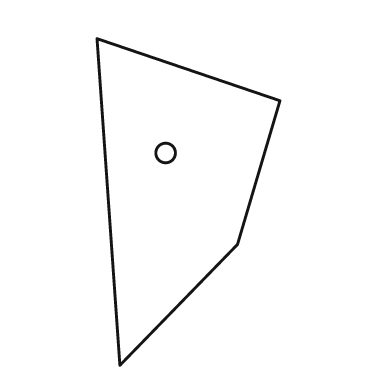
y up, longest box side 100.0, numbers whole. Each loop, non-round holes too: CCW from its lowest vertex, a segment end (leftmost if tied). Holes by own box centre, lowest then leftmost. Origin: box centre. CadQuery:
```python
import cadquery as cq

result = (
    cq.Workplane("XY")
    .moveTo(-21.0, -50.0)
    .lineTo(15.0, -13.0)
    .lineTo(28.0, 31.0)
    .lineTo(-28.0, 50.0)
    .close()
    .moveTo(-7.0, 15.0)
    .circle(3.0)
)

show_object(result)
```